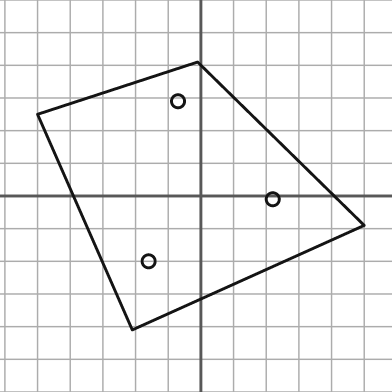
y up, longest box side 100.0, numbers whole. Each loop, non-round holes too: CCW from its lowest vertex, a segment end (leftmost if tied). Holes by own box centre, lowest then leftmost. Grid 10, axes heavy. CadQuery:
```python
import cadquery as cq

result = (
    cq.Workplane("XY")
    .moveTo(-21.0, -41.0)
    .lineTo(50.0, -9.0)
    .lineTo(-1.0, 41.0)
    .lineTo(-50.0, 25.0)
    .close()
    .moveTo(-16.0, -20.0)
    .circle(2.0)
    .moveTo(22.0, -1.0)
    .circle(2.0)
    .moveTo(-7.0, 29.0)
    .circle(2.0)
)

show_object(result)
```